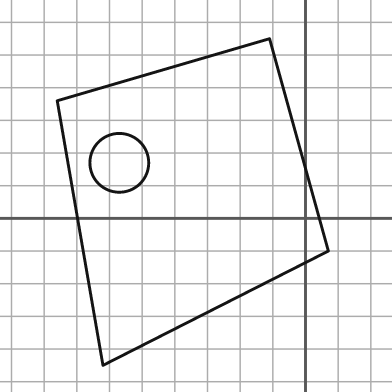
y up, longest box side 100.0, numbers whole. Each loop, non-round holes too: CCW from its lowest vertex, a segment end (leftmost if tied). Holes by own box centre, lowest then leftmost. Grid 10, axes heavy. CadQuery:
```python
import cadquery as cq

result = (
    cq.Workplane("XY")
    .moveTo(-62.0, -45.0)
    .lineTo(7.0, -10.0)
    .lineTo(-11.0, 55.0)
    .lineTo(-76.0, 36.0)
    .close()
    .moveTo(-57.0, 17.0)
    .circle(9.0)
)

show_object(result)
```